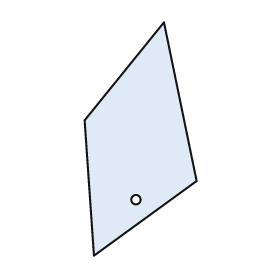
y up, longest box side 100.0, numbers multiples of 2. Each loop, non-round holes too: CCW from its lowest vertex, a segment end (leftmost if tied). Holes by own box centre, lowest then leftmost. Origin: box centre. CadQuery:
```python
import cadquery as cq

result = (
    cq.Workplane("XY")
    .moveTo(-20.0, -50.0)
    .lineTo(24.0, -18.0)
    .lineTo(10.0, 50.0)
    .lineTo(-24.0, 8.0)
    .close()
    .moveTo(-2.0, -26.0)
    .circle(2.0)
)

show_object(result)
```